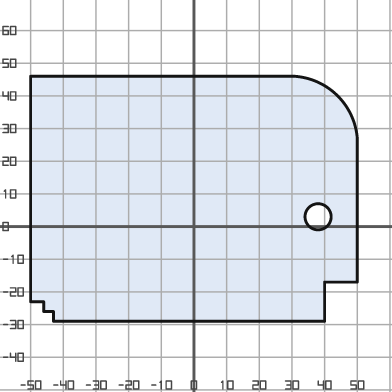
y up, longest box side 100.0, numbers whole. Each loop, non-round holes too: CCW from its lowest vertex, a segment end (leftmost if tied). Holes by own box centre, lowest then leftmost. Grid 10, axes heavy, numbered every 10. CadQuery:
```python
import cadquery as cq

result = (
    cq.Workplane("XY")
    .moveTo(-43.0, -29.0)
    .lineTo(40.0, -29.0)
    .lineTo(40.0, -17.0)
    .lineTo(50.0, -17.0)
    .lineTo(50.0, 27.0)
    .threePointArc((44.0, 40.0), (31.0, 46.0))
    .lineTo(-50.0, 46.0)
    .lineTo(-50.0, -23.0)
    .lineTo(-46.0, -23.0)
    .lineTo(-46.0, -26.0)
    .lineTo(-43.0, -26.0)
    .close()
    .moveTo(38.0, 3.0)
    .circle(4.0)
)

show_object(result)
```